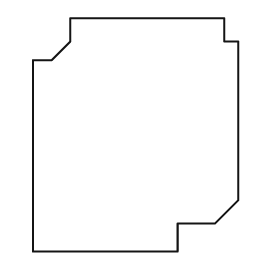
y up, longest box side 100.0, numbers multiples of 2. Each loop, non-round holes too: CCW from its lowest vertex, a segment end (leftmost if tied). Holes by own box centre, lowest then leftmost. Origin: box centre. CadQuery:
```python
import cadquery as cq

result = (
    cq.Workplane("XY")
    .moveTo(-44.0, -50.0)
    .lineTo(18.0, -50.0)
    .lineTo(18.0, -38.0)
    .lineTo(34.0, -38.0)
    .lineTo(44.0, -28.0)
    .lineTo(44.0, 40.0)
    .lineTo(38.0, 40.0)
    .lineTo(38.0, 50.0)
    .lineTo(-28.0, 50.0)
    .lineTo(-28.0, 40.0)
    .lineTo(-36.0, 32.0)
    .lineTo(-44.0, 32.0)
    .close()
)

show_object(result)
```